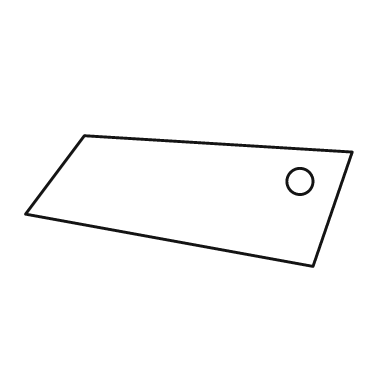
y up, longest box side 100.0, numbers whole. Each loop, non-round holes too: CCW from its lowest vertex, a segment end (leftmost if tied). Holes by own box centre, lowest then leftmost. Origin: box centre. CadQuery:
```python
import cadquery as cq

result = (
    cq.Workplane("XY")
    .moveTo(38.0, -20.0)
    .lineTo(50.0, 15.0)
    .lineTo(-32.0, 20.0)
    .lineTo(-50.0, -4.0)
    .close()
    .moveTo(34.0, 6.0)
    .circle(4.0)
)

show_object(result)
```